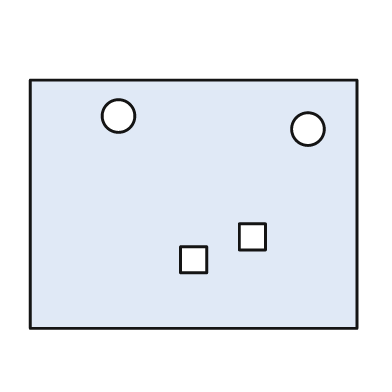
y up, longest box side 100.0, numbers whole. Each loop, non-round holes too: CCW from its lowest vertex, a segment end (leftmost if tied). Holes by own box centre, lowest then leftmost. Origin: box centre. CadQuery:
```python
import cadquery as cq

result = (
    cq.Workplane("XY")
    .moveTo(-50.0, -38.0)
    .lineTo(50.0, -38.0)
    .lineTo(50.0, 38.0)
    .lineTo(-50.0, 38.0)
    .close()
    .moveTo(-4.0, -21.0)
    .lineTo(4.0, -21.0)
    .lineTo(4.0, -13.0)
    .lineTo(-4.0, -13.0)
    .close()
    .moveTo(14.0, -14.0)
    .lineTo(22.0, -14.0)
    .lineTo(22.0, -6.0)
    .lineTo(14.0, -6.0)
    .close()
    .moveTo(35.0, 23.0)
    .circle(5.0)
    .moveTo(-23.0, 27.0)
    .circle(5.0)
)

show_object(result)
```